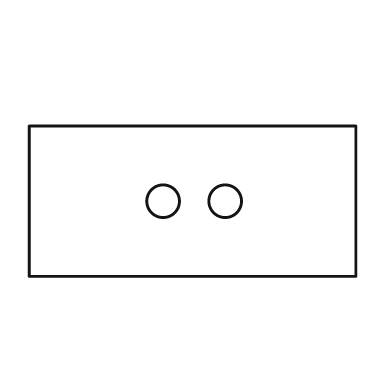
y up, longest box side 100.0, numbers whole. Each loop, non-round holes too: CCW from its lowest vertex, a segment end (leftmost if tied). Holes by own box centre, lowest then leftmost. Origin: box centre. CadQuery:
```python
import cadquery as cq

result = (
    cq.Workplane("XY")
    .moveTo(-50.0, -23.0)
    .lineTo(50.0, -23.0)
    .lineTo(50.0, 23.0)
    .lineTo(-50.0, 23.0)
    .close()
    .moveTo(-9.0, 0.0)
    .circle(5.0)
    .moveTo(10.0, 0.0)
    .circle(5.0)
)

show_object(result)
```